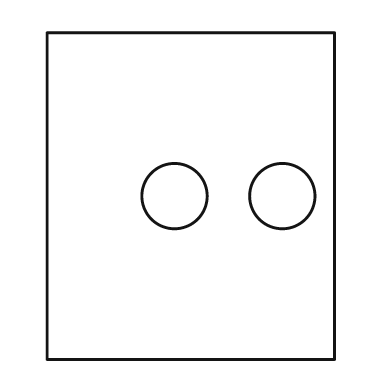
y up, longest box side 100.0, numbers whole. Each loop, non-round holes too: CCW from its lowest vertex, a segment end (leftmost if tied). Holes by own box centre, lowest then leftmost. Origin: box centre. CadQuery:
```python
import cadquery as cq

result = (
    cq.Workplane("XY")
    .moveTo(-44.0, -50.0)
    .lineTo(44.0, -50.0)
    .lineTo(44.0, 50.0)
    .lineTo(-44.0, 50.0)
    .close()
    .moveTo(-5.0, 0.0)
    .circle(10.0)
    .moveTo(28.0, 0.0)
    .circle(10.0)
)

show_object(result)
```